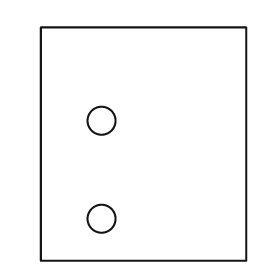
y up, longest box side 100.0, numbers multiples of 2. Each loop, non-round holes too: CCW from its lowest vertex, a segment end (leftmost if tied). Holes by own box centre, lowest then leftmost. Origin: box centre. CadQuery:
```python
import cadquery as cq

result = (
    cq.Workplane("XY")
    .moveTo(-44.0, -50.0)
    .lineTo(44.0, -50.0)
    .lineTo(44.0, 50.0)
    .lineTo(-44.0, 50.0)
    .close()
    .moveTo(-18.0, -32.0)
    .circle(6.0)
    .moveTo(-18.0, 10.0)
    .circle(6.0)
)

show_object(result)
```